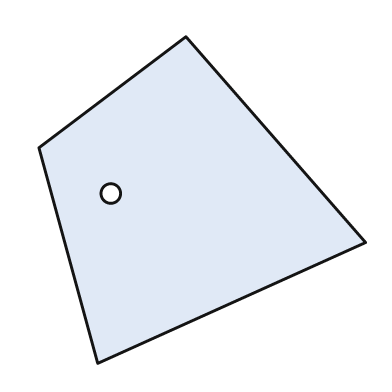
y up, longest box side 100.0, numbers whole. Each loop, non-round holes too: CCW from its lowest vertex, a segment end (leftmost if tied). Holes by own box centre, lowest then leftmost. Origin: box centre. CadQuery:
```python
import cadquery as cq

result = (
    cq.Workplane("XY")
    .moveTo(-32.0, -50.0)
    .lineTo(50.0, -13.0)
    .lineTo(-5.0, 50.0)
    .lineTo(-50.0, 16.0)
    .close()
    .moveTo(-28.0, 2.0)
    .circle(3.0)
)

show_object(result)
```